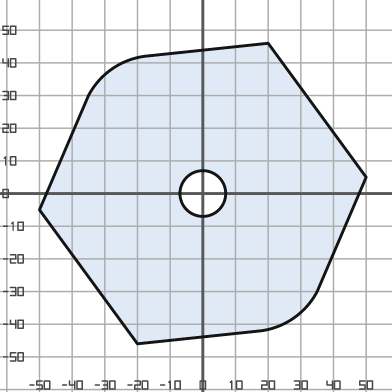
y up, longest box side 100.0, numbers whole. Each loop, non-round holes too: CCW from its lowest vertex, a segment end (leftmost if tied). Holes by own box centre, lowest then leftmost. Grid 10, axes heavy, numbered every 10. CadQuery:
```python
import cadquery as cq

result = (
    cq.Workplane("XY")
    .moveTo(-20.0, -46.0)
    .lineTo(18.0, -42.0)
    .threePointArc((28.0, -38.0), (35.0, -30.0))
    .lineTo(50.0, 5.0)
    .lineTo(20.0, 46.0)
    .lineTo(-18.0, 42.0)
    .threePointArc((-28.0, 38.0), (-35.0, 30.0))
    .lineTo(-50.0, -5.0)
    .close()
    .moveTo(0.0, 0.0)
    .circle(7.0)
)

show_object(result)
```